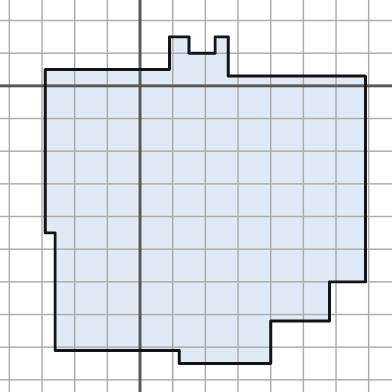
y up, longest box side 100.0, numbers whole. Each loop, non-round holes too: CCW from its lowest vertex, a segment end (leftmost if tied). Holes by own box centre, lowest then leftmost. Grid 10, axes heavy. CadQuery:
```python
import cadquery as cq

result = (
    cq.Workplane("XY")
    .moveTo(12.0, -85.0)
    .lineTo(40.0, -85.0)
    .lineTo(40.0, -72.0)
    .lineTo(58.0, -72.0)
    .lineTo(58.0, -60.0)
    .lineTo(69.0, -60.0)
    .lineTo(69.0, 3.0)
    .lineTo(27.0, 3.0)
    .lineTo(27.0, 15.0)
    .lineTo(23.0, 15.0)
    .lineTo(23.0, 10.0)
    .lineTo(15.0, 10.0)
    .lineTo(15.0, 15.0)
    .lineTo(9.0, 15.0)
    .lineTo(9.0, 5.0)
    .lineTo(-29.0, 5.0)
    .lineTo(-29.0, -45.0)
    .lineTo(-26.0, -45.0)
    .lineTo(-26.0, -81.0)
    .lineTo(12.0, -81.0)
    .close()
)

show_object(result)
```